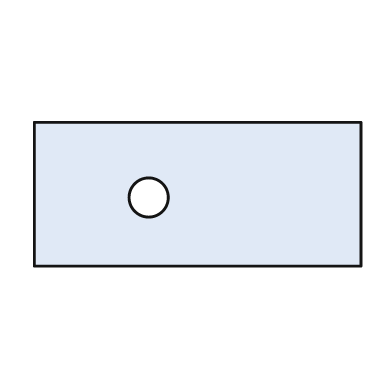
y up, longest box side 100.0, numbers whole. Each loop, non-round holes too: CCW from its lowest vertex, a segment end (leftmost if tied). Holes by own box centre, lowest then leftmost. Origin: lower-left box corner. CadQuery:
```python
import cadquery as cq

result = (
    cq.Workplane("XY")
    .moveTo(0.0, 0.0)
    .lineTo(100.0, 0.0)
    .lineTo(100.0, 44.0)
    .lineTo(0.0, 44.0)
    .close()
    .moveTo(35.0, 21.0)
    .circle(6.0)
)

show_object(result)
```